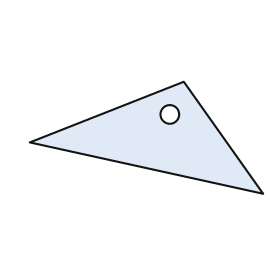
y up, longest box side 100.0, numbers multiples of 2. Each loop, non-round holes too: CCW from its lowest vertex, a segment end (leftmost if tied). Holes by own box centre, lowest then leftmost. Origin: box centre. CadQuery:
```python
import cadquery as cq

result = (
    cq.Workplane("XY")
    .moveTo(50.0, -24.0)
    .lineTo(16.0, 24.0)
    .lineTo(-50.0, -2.0)
    .close()
    .moveTo(10.0, 10.0)
    .circle(4.0)
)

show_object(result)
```